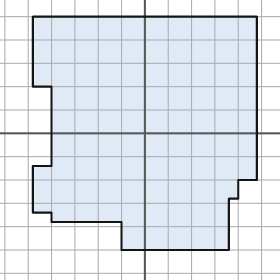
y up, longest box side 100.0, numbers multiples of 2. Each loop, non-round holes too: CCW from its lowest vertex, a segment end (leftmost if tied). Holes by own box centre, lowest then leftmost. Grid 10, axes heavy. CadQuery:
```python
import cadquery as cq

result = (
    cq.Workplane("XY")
    .moveTo(-10.0, -50.0)
    .lineTo(36.0, -50.0)
    .lineTo(36.0, -28.0)
    .lineTo(40.0, -28.0)
    .lineTo(40.0, -20.0)
    .lineTo(48.0, -20.0)
    .lineTo(48.0, 50.0)
    .lineTo(-48.0, 50.0)
    .lineTo(-48.0, 20.0)
    .lineTo(-40.0, 20.0)
    .lineTo(-40.0, -14.0)
    .lineTo(-48.0, -14.0)
    .lineTo(-48.0, -34.0)
    .lineTo(-40.0, -34.0)
    .lineTo(-40.0, -38.0)
    .lineTo(-10.0, -38.0)
    .close()
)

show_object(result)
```